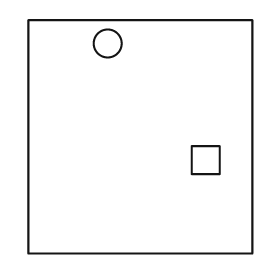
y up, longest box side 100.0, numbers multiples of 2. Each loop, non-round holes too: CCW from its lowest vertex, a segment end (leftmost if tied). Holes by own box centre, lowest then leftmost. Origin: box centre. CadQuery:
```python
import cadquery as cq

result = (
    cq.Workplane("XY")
    .moveTo(-48.0, -50.0)
    .lineTo(48.0, -50.0)
    .lineTo(48.0, 50.0)
    .lineTo(-48.0, 50.0)
    .close()
    .moveTo(22.0, -16.0)
    .lineTo(34.0, -16.0)
    .lineTo(34.0, -4.0)
    .lineTo(22.0, -4.0)
    .close()
    .moveTo(-14.0, 40.0)
    .circle(6.0)
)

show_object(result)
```